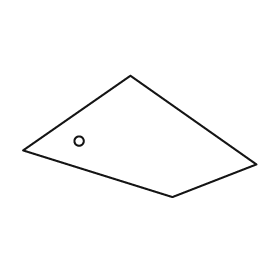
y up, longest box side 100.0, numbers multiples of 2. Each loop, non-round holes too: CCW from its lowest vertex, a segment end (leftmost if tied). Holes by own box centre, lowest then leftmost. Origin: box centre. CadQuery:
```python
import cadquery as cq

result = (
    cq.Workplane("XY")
    .moveTo(14.0, -26.0)
    .lineTo(50.0, -12.0)
    .lineTo(-4.0, 26.0)
    .lineTo(-50.0, -6.0)
    .close()
    .moveTo(-26.0, -2.0)
    .circle(2.0)
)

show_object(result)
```